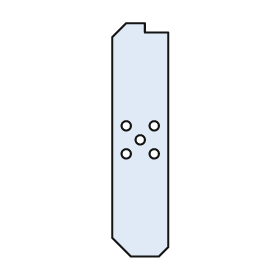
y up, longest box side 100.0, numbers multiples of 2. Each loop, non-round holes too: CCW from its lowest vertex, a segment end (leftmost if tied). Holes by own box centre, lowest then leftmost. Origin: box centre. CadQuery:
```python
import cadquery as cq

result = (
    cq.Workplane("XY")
    .moveTo(-4.0, -50.0)
    .lineTo(8.0, -50.0)
    .lineTo(12.0, -46.0)
    .lineTo(12.0, 46.0)
    .lineTo(2.0, 46.0)
    .lineTo(2.0, 50.0)
    .lineTo(-6.0, 50.0)
    .lineTo(-12.0, 44.0)
    .lineTo(-12.0, -42.0)
    .close()
    .moveTo(-6.0, -6.0)
    .circle(2.0)
    .moveTo(6.0, -6.0)
    .circle(2.0)
    .moveTo(0.0, 0.0)
    .circle(2.0)
    .moveTo(-6.0, 6.0)
    .circle(2.0)
    .moveTo(6.0, 6.0)
    .circle(2.0)
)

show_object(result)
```